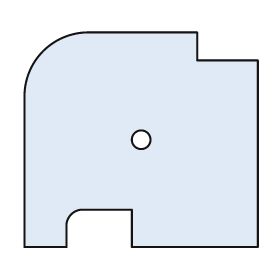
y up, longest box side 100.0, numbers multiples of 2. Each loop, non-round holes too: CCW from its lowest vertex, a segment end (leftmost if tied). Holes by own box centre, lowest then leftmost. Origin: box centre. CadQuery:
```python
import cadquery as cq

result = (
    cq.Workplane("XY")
    .moveTo(-50.0, -46.0)
    .lineTo(-32.0, -46.0)
    .lineTo(-32.0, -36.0)
    .threePointArc((-30.0, -32.0), (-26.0, -30.0))
    .lineTo(-4.0, -30.0)
    .lineTo(-4.0, -46.0)
    .lineTo(50.0, -46.0)
    .lineTo(50.0, 34.0)
    .lineTo(24.0, 34.0)
    .lineTo(24.0, 46.0)
    .lineTo(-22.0, 46.0)
    .threePointArc((-42.0, 38.0), (-50.0, 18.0))
    .close()
    .moveTo(0.0, 0.0)
    .circle(4.0)
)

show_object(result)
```